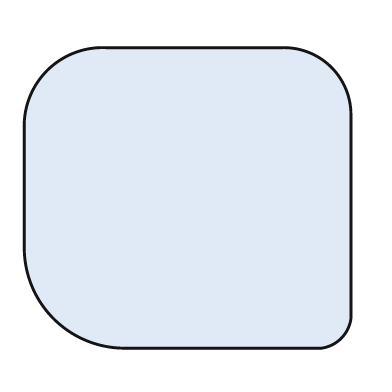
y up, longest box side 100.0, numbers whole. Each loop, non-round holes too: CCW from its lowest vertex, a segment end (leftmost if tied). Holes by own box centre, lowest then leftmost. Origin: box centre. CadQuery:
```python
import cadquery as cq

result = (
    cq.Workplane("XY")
    .moveTo(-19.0, -46.0)
    .lineTo(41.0, -46.0)
    .threePointArc((47.0, -43.0), (50.0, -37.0))
    .lineTo(50.0, 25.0)
    .threePointArc((44.0, 40.0), (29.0, 46.0))
    .lineTo(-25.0, 46.0)
    .threePointArc((-43.0, 39.0), (-50.0, 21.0))
    .lineTo(-50.0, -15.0)
    .threePointArc((-41.0, -37.0), (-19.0, -46.0))
    .close()
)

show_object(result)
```